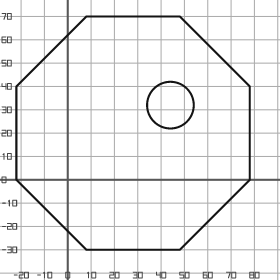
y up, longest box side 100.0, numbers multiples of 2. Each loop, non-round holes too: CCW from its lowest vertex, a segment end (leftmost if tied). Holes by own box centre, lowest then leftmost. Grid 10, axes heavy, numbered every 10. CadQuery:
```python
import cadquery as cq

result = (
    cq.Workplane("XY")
    .moveTo(8.0, -30.0)
    .lineTo(48.0, -30.0)
    .lineTo(78.0, 0.0)
    .lineTo(78.0, 40.0)
    .lineTo(48.0, 70.0)
    .lineTo(8.0, 70.0)
    .lineTo(-22.0, 40.0)
    .lineTo(-22.0, 0.0)
    .close()
    .moveTo(44.0, 32.0)
    .circle(10.0)
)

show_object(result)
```